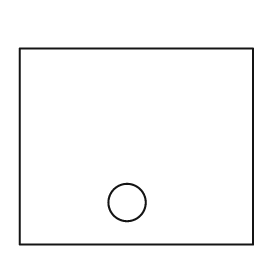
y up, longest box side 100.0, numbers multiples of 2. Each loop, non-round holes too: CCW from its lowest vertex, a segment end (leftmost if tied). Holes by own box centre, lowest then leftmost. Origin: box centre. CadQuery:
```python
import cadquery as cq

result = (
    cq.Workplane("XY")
    .moveTo(-50.0, -42.0)
    .lineTo(50.0, -42.0)
    .lineTo(50.0, 42.0)
    .lineTo(-50.0, 42.0)
    .close()
    .moveTo(-4.0, -24.0)
    .circle(8.0)
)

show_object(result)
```